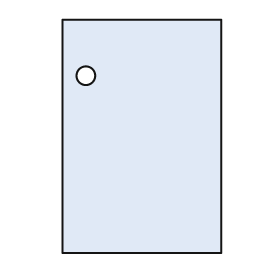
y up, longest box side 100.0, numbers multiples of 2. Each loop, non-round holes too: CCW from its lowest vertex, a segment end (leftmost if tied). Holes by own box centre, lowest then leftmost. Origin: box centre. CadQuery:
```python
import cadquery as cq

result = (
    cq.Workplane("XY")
    .moveTo(-34.0, -50.0)
    .lineTo(34.0, -50.0)
    .lineTo(34.0, 50.0)
    .lineTo(-34.0, 50.0)
    .close()
    .moveTo(-24.0, 26.0)
    .circle(4.0)
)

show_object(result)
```